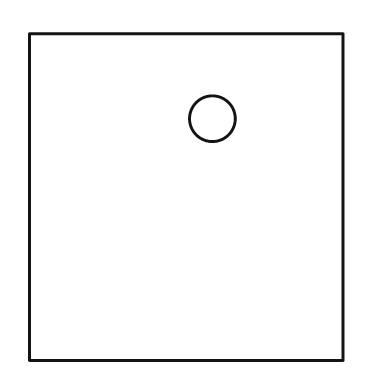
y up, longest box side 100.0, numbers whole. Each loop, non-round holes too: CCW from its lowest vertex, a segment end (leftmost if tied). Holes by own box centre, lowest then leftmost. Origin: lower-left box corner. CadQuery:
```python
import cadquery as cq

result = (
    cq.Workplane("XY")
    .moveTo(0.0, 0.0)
    .lineTo(96.0, 0.0)
    .lineTo(96.0, 100.0)
    .lineTo(0.0, 100.0)
    .close()
    .moveTo(56.0, 74.0)
    .circle(7.0)
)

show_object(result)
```